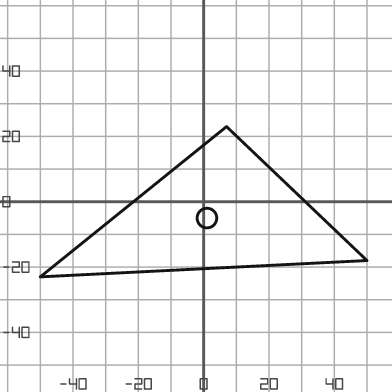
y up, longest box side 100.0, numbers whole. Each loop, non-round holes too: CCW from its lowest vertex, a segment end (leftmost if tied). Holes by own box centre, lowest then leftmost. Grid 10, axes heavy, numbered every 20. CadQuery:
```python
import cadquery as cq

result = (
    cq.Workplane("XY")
    .moveTo(-50.0, -23.0)
    .lineTo(50.0, -18.0)
    .lineTo(7.0, 23.0)
    .close()
    .moveTo(1.0, -5.0)
    .circle(3.0)
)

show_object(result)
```